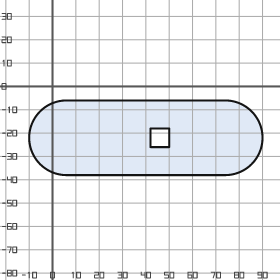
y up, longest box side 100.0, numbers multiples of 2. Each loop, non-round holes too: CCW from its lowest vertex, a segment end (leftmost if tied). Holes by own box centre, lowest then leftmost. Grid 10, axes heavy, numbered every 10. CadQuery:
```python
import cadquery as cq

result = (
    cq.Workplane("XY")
    .moveTo(6.0, -38.0)
    .lineTo(74.0, -38.0)
    .threePointArc((90.0, -22.0), (74.0, -6.0))
    .lineTo(6.0, -6.0)
    .threePointArc((-10.0, -22.0), (6.0, -38.0))
    .close()
    .moveTo(42.0, -26.0)
    .lineTo(50.0, -26.0)
    .lineTo(50.0, -18.0)
    .lineTo(42.0, -18.0)
    .close()
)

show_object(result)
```